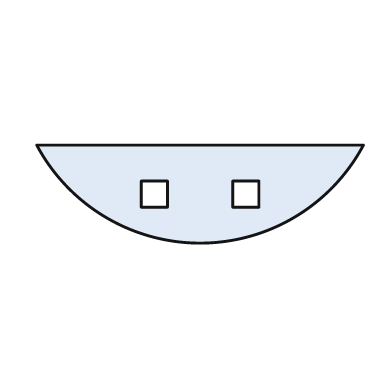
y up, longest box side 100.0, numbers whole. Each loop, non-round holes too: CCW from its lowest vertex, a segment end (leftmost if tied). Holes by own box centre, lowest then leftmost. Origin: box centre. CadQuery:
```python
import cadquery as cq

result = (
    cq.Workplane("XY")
    .moveTo(-50.0, 15.0)
    .threePointArc((0.0, -15.0), (50.0, 15.0))
    .close()
    .moveTo(-18.0, -4.0)
    .lineTo(-10.0, -4.0)
    .lineTo(-10.0, 4.0)
    .lineTo(-18.0, 4.0)
    .close()
    .moveTo(10.0, -4.0)
    .lineTo(18.0, -4.0)
    .lineTo(18.0, 4.0)
    .lineTo(10.0, 4.0)
    .close()
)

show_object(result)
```